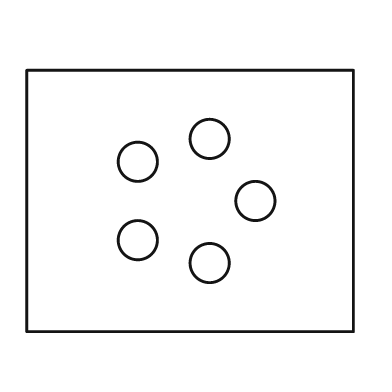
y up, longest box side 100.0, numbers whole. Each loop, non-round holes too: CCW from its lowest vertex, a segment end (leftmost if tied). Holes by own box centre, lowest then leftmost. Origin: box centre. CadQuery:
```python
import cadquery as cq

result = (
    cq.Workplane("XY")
    .moveTo(-50.0, -40.0)
    .lineTo(50.0, -40.0)
    .lineTo(50.0, 40.0)
    .lineTo(-50.0, 40.0)
    .close()
    .moveTo(6.0, -19.0)
    .circle(6.0)
    .moveTo(-16.0, -12.0)
    .circle(6.0)
    .moveTo(20.0, 0.0)
    .circle(6.0)
    .moveTo(-16.0, 12.0)
    .circle(6.0)
    .moveTo(6.0, 19.0)
    .circle(6.0)
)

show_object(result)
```